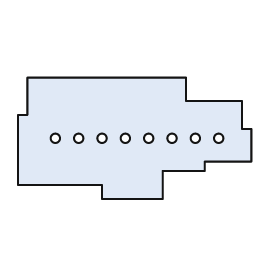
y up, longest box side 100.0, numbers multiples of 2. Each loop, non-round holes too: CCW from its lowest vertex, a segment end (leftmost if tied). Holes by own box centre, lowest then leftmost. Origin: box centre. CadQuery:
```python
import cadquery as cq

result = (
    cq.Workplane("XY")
    .moveTo(-14.0, -26.0)
    .lineTo(12.0, -26.0)
    .lineTo(12.0, -14.0)
    .lineTo(30.0, -14.0)
    .lineTo(30.0, -10.0)
    .lineTo(50.0, -10.0)
    .lineTo(50.0, 4.0)
    .lineTo(46.0, 4.0)
    .lineTo(46.0, 16.0)
    .lineTo(22.0, 16.0)
    .lineTo(22.0, 26.0)
    .lineTo(-46.0, 26.0)
    .lineTo(-46.0, 10.0)
    .lineTo(-50.0, 10.0)
    .lineTo(-50.0, -20.0)
    .lineTo(-14.0, -20.0)
    .close()
    .moveTo(-34.0, 0.0)
    .circle(2.0)
    .moveTo(-24.0, 0.0)
    .circle(2.0)
    .moveTo(-14.0, 0.0)
    .circle(2.0)
    .moveTo(-4.0, 0.0)
    .circle(2.0)
    .moveTo(6.0, 0.0)
    .circle(2.0)
    .moveTo(16.0, 0.0)
    .circle(2.0)
    .moveTo(26.0, 0.0)
    .circle(2.0)
    .moveTo(36.0, 0.0)
    .circle(2.0)
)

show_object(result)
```